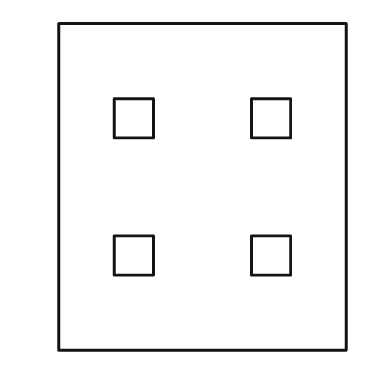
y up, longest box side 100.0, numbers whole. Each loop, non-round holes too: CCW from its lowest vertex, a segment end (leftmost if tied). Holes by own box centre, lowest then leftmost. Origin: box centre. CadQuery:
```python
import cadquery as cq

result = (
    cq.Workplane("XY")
    .moveTo(-44.0, -50.0)
    .lineTo(44.0, -50.0)
    .lineTo(44.0, 50.0)
    .lineTo(-44.0, 50.0)
    .close()
    .moveTo(-27.0, -27.0)
    .lineTo(-15.0, -27.0)
    .lineTo(-15.0, -15.0)
    .lineTo(-27.0, -15.0)
    .close()
    .moveTo(15.0, -27.0)
    .lineTo(27.0, -27.0)
    .lineTo(27.0, -15.0)
    .lineTo(15.0, -15.0)
    .close()
    .moveTo(-27.0, 15.0)
    .lineTo(-15.0, 15.0)
    .lineTo(-15.0, 27.0)
    .lineTo(-27.0, 27.0)
    .close()
    .moveTo(15.0, 15.0)
    .lineTo(27.0, 15.0)
    .lineTo(27.0, 27.0)
    .lineTo(15.0, 27.0)
    .close()
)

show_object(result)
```